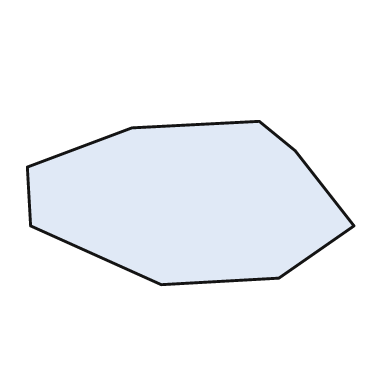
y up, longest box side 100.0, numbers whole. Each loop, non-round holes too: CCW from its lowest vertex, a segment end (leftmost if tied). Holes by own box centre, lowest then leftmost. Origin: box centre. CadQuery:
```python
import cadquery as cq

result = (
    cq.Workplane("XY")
    .moveTo(-9.0, -25.0)
    .lineTo(27.0, -23.0)
    .lineTo(50.0, -7.0)
    .lineTo(32.0, 16.0)
    .lineTo(21.0, 25.0)
    .lineTo(-18.0, 23.0)
    .lineTo(-50.0, 11.0)
    .lineTo(-49.0, -7.0)
    .close()
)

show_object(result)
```